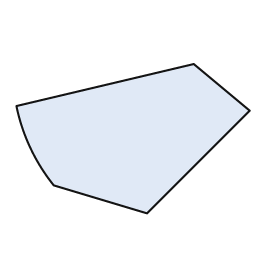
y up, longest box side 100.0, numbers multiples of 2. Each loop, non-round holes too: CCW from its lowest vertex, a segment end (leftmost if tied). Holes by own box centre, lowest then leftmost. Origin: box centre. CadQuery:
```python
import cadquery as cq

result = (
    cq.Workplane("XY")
    .moveTo(6.0, -32.0)
    .lineTo(50.0, 12.0)
    .lineTo(26.0, 32.0)
    .lineTo(-50.0, 14.0)
    .threePointArc((-44.0, -4.0), (-34.0, -20.0))
    .close()
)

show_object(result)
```